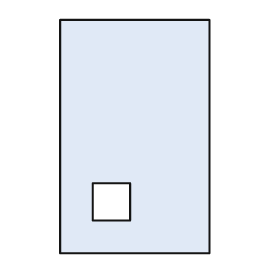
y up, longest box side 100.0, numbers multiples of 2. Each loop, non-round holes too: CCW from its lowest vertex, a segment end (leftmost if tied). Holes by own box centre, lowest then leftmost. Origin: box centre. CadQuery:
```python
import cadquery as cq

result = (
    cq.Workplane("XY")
    .moveTo(-32.0, -50.0)
    .lineTo(32.0, -50.0)
    .lineTo(32.0, 50.0)
    .lineTo(-32.0, 50.0)
    .close()
    .moveTo(-18.0, -36.0)
    .lineTo(-2.0, -36.0)
    .lineTo(-2.0, -20.0)
    .lineTo(-18.0, -20.0)
    .close()
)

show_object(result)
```